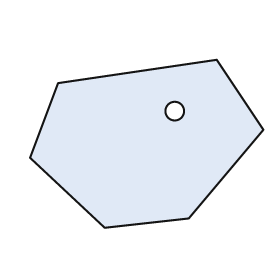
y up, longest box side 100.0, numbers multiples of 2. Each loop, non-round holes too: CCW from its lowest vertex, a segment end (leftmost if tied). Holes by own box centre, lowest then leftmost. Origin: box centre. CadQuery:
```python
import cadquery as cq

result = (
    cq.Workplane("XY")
    .moveTo(-18.0, -36.0)
    .lineTo(18.0, -32.0)
    .lineTo(50.0, 6.0)
    .lineTo(30.0, 36.0)
    .lineTo(-38.0, 26.0)
    .lineTo(-50.0, -6.0)
    .close()
    .moveTo(12.0, 14.0)
    .circle(4.0)
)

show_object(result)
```